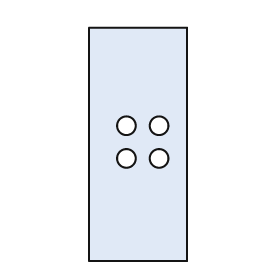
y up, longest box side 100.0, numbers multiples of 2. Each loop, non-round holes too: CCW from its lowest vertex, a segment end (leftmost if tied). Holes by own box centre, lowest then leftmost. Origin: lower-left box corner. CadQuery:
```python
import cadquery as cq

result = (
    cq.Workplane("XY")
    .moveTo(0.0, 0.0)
    .lineTo(42.0, 0.0)
    .lineTo(42.0, 100.0)
    .lineTo(0.0, 100.0)
    .close()
    .moveTo(16.0, 44.0)
    .circle(4.0)
    .moveTo(30.0, 44.0)
    .circle(4.0)
    .moveTo(16.0, 58.0)
    .circle(4.0)
    .moveTo(30.0, 58.0)
    .circle(4.0)
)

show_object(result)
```